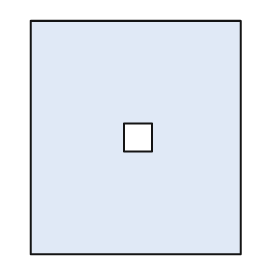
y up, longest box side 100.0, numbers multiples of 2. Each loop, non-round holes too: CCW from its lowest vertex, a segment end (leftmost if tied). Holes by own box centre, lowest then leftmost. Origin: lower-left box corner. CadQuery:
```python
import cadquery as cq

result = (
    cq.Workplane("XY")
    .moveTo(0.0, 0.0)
    .lineTo(90.0, 0.0)
    .lineTo(90.0, 100.0)
    .lineTo(0.0, 100.0)
    .close()
    .moveTo(40.0, 44.0)
    .lineTo(52.0, 44.0)
    .lineTo(52.0, 56.0)
    .lineTo(40.0, 56.0)
    .close()
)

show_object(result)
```